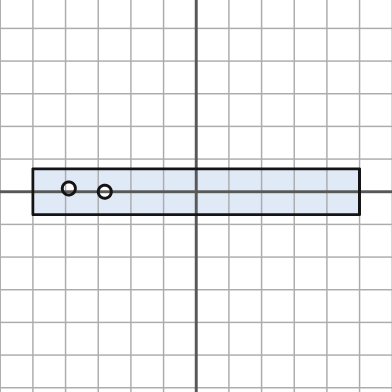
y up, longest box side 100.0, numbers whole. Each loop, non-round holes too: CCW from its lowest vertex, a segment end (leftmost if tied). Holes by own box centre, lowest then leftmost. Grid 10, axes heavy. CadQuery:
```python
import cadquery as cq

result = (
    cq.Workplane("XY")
    .moveTo(-50.0, -7.0)
    .lineTo(50.0, -7.0)
    .lineTo(50.0, 7.0)
    .lineTo(-50.0, 7.0)
    .close()
    .moveTo(-28.0, 0.0)
    .circle(2.0)
    .moveTo(-39.0, 1.0)
    .circle(2.0)
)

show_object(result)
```